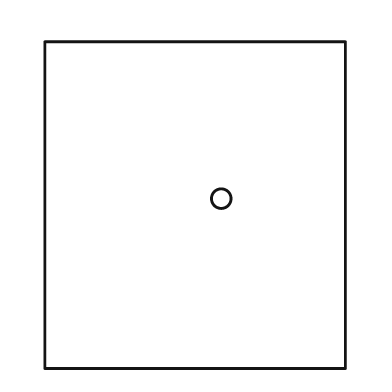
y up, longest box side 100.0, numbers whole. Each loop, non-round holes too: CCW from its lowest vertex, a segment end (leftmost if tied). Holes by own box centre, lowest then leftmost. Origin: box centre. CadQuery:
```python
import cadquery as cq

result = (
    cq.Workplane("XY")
    .moveTo(-46.0, -50.0)
    .lineTo(46.0, -50.0)
    .lineTo(46.0, 50.0)
    .lineTo(-46.0, 50.0)
    .close()
    .moveTo(8.0, 2.0)
    .circle(3.0)
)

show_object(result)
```